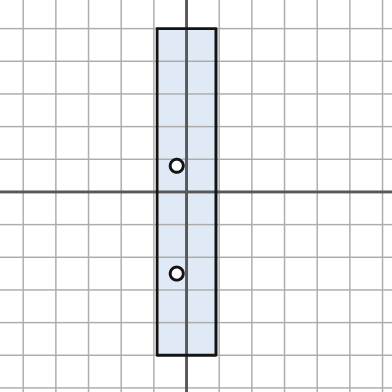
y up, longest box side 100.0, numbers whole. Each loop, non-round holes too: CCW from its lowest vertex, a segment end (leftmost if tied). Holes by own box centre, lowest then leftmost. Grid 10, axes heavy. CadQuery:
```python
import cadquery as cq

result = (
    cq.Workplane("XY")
    .moveTo(-9.0, -50.0)
    .lineTo(9.0, -50.0)
    .lineTo(9.0, 50.0)
    .lineTo(-9.0, 50.0)
    .close()
    .moveTo(-3.0, -25.0)
    .circle(2.0)
    .moveTo(-3.0, 8.0)
    .circle(2.0)
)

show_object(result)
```